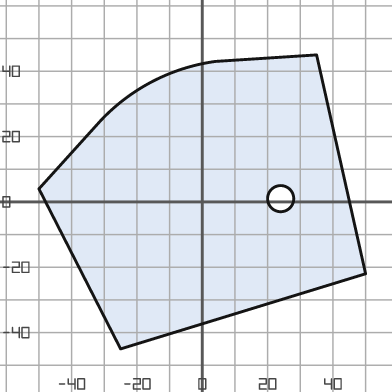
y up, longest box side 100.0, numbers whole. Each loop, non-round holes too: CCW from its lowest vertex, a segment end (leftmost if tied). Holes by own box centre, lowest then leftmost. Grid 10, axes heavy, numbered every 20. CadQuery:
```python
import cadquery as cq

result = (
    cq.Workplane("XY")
    .moveTo(-25.0, -45.0)
    .lineTo(50.0, -22.0)
    .lineTo(35.0, 45.0)
    .lineTo(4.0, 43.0)
    .threePointArc((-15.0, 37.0), (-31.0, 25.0))
    .lineTo(-50.0, 4.0)
    .close()
    .moveTo(24.0, 1.0)
    .circle(4.0)
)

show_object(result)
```